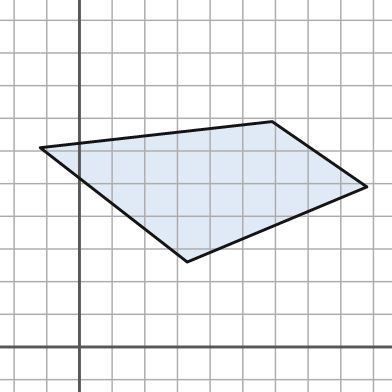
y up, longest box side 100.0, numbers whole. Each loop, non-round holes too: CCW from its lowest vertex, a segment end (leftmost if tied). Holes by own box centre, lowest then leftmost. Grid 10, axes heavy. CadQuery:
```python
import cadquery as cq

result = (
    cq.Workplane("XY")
    .moveTo(33.0, 26.0)
    .lineTo(88.0, 49.0)
    .lineTo(59.0, 69.0)
    .lineTo(-12.0, 61.0)
    .close()
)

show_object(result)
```